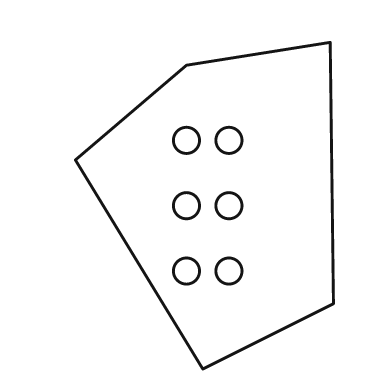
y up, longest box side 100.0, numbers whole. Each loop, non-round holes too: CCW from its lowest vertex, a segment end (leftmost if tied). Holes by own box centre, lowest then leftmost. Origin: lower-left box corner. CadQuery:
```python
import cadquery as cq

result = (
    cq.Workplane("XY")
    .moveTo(39.0, 0.0)
    .lineTo(79.0, 20.0)
    .lineTo(78.0, 100.0)
    .lineTo(34.0, 93.0)
    .lineTo(0.0, 64.0)
    .close()
    .moveTo(34.0, 30.0)
    .circle(4.0)
    .moveTo(47.0, 30.0)
    .circle(4.0)
    .moveTo(34.0, 50.0)
    .circle(4.0)
    .moveTo(47.0, 50.0)
    .circle(4.0)
    .moveTo(34.0, 70.0)
    .circle(4.0)
    .moveTo(47.0, 70.0)
    .circle(4.0)
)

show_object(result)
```